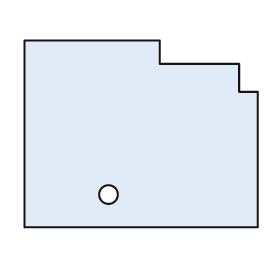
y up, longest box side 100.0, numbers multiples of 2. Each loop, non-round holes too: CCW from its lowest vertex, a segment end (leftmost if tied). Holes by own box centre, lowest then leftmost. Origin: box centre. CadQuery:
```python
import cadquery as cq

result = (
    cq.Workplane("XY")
    .moveTo(-50.0, -40.0)
    .lineTo(50.0, -40.0)
    .lineTo(50.0, 18.0)
    .lineTo(42.0, 18.0)
    .lineTo(42.0, 30.0)
    .lineTo(8.0, 30.0)
    .lineTo(8.0, 40.0)
    .lineTo(-50.0, 40.0)
    .close()
    .moveTo(-14.0, -26.0)
    .circle(4.0)
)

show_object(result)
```